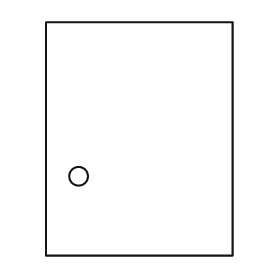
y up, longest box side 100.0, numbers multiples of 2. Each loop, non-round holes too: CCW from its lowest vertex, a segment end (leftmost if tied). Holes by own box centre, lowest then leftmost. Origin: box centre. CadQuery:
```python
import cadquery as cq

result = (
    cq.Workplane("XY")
    .moveTo(-40.0, -50.0)
    .lineTo(40.0, -50.0)
    .lineTo(40.0, 50.0)
    .lineTo(-40.0, 50.0)
    .close()
    .moveTo(-26.0, -16.0)
    .circle(4.0)
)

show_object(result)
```